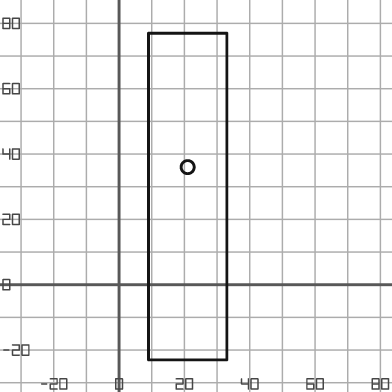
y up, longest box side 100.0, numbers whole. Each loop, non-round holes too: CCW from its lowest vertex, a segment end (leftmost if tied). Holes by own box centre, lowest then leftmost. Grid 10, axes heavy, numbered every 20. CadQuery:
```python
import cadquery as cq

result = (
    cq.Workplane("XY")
    .moveTo(9.0, -23.0)
    .lineTo(33.0, -23.0)
    .lineTo(33.0, 77.0)
    .lineTo(9.0, 77.0)
    .close()
    .moveTo(21.0, 36.0)
    .circle(2.0)
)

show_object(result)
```